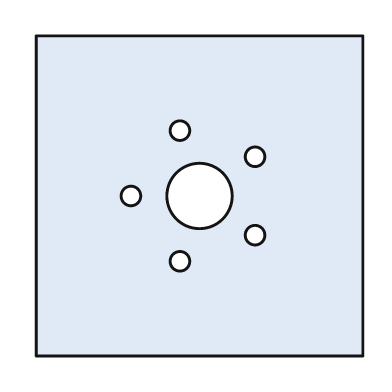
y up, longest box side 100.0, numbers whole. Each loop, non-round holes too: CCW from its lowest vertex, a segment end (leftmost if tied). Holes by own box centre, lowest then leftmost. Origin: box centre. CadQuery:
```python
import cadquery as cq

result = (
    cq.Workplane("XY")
    .moveTo(-50.0, -49.0)
    .lineTo(50.0, -49.0)
    .lineTo(50.0, 49.0)
    .lineTo(-50.0, 49.0)
    .close()
    .moveTo(-6.0, -20.0)
    .circle(3.0)
    .moveTo(17.0, -12.0)
    .circle(3.0)
    .moveTo(-21.0, 0.0)
    .circle(3.0)
    .moveTo(0.0, 0.0)
    .circle(10.0)
    .moveTo(17.0, 12.0)
    .circle(3.0)
    .moveTo(-6.0, 20.0)
    .circle(3.0)
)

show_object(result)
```